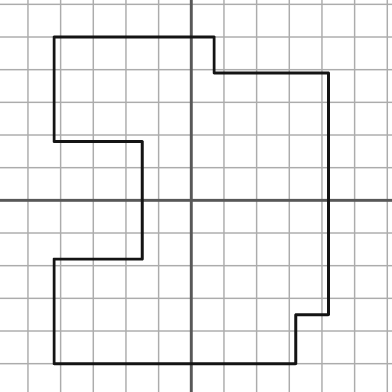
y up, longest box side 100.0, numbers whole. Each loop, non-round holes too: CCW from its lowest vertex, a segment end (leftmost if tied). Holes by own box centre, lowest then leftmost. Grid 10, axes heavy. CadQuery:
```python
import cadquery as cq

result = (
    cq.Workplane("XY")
    .moveTo(-42.0, -50.0)
    .lineTo(32.0, -50.0)
    .lineTo(32.0, -35.0)
    .lineTo(42.0, -35.0)
    .lineTo(42.0, 39.0)
    .lineTo(7.0, 39.0)
    .lineTo(7.0, 50.0)
    .lineTo(-42.0, 50.0)
    .lineTo(-42.0, 18.0)
    .lineTo(-15.0, 18.0)
    .lineTo(-15.0, -18.0)
    .lineTo(-42.0, -18.0)
    .close()
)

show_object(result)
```